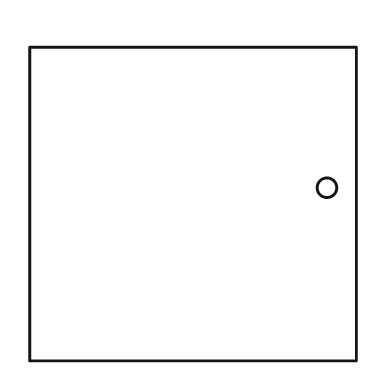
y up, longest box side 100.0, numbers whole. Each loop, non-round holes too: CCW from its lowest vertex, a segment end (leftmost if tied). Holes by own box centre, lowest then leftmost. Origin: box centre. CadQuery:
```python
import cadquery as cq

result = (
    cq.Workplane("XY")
    .moveTo(-50.0, -48.0)
    .lineTo(50.0, -48.0)
    .lineTo(50.0, 48.0)
    .lineTo(-50.0, 48.0)
    .close()
    .moveTo(41.0, 5.0)
    .circle(3.0)
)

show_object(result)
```